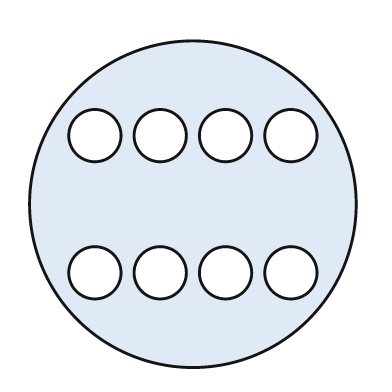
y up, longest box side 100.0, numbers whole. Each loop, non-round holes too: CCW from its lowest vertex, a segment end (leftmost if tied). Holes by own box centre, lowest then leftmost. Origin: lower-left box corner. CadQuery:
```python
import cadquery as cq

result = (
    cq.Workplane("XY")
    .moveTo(50.0, 50.0)
    .circle(50.0)
    .moveTo(20.0, 29.0)
    .circle(8.0)
    .moveTo(40.0, 29.0)
    .circle(8.0)
    .moveTo(60.0, 29.0)
    .circle(8.0)
    .moveTo(80.0, 29.0)
    .circle(8.0)
    .moveTo(20.0, 71.0)
    .circle(8.0)
    .moveTo(40.0, 71.0)
    .circle(8.0)
    .moveTo(60.0, 71.0)
    .circle(8.0)
    .moveTo(80.0, 71.0)
    .circle(8.0)
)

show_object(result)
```